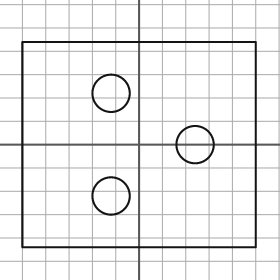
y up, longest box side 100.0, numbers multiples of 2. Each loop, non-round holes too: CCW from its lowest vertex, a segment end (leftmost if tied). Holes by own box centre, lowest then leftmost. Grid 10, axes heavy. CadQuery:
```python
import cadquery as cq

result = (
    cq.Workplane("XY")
    .moveTo(-50.0, -44.0)
    .lineTo(50.0, -44.0)
    .lineTo(50.0, 44.0)
    .lineTo(-50.0, 44.0)
    .close()
    .moveTo(-12.0, -22.0)
    .circle(8.0)
    .moveTo(24.0, 0.0)
    .circle(8.0)
    .moveTo(-12.0, 22.0)
    .circle(8.0)
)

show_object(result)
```